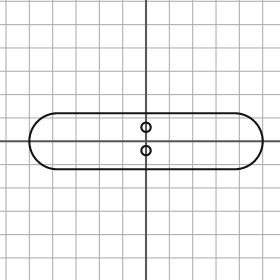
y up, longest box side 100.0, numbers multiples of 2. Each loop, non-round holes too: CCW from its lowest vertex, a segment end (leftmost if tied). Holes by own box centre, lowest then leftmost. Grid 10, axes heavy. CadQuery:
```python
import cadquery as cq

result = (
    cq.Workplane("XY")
    .moveTo(-38.0, -12.0)
    .lineTo(38.0, -12.0)
    .threePointArc((50.0, 0.0), (38.0, 12.0))
    .lineTo(-38.0, 12.0)
    .threePointArc((-50.0, 0.0), (-38.0, -12.0))
    .close()
    .moveTo(0.0, -4.0)
    .circle(2.0)
    .moveTo(0.0, 6.0)
    .circle(2.0)
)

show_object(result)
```